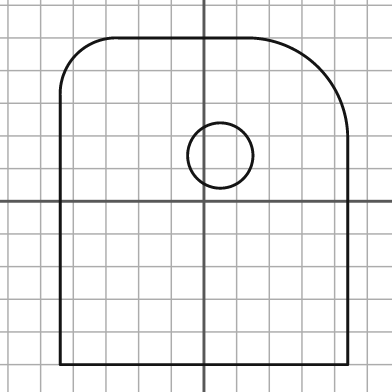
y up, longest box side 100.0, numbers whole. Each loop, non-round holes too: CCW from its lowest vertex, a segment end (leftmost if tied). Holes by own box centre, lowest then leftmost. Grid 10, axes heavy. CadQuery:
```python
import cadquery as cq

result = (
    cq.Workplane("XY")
    .moveTo(-44.0, -50.0)
    .lineTo(44.0, -50.0)
    .lineTo(44.0, 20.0)
    .threePointArc((35.0, 41.0), (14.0, 50.0))
    .lineTo(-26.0, 50.0)
    .threePointArc((-39.0, 45.0), (-44.0, 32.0))
    .close()
    .moveTo(5.0, 14.0)
    .circle(10.0)
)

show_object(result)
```